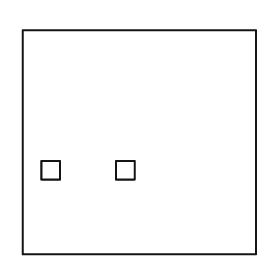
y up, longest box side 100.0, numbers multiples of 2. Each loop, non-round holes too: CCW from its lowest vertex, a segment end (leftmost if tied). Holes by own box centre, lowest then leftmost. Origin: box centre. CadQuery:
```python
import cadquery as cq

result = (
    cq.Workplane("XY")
    .moveTo(-50.0, -48.0)
    .lineTo(50.0, -48.0)
    .lineTo(50.0, 48.0)
    .lineTo(-50.0, 48.0)
    .close()
    .moveTo(-42.0, -16.0)
    .lineTo(-34.0, -16.0)
    .lineTo(-34.0, -8.0)
    .lineTo(-42.0, -8.0)
    .close()
    .moveTo(-10.0, -16.0)
    .lineTo(-2.0, -16.0)
    .lineTo(-2.0, -8.0)
    .lineTo(-10.0, -8.0)
    .close()
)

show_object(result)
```